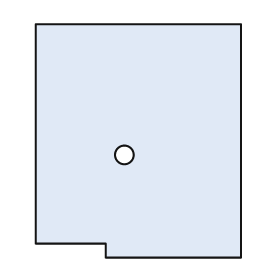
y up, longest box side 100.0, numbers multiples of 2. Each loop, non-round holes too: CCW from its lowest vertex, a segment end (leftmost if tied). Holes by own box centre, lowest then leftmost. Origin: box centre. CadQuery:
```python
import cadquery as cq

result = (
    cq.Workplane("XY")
    .moveTo(-14.0, -50.0)
    .lineTo(44.0, -50.0)
    .lineTo(44.0, 50.0)
    .lineTo(-44.0, 50.0)
    .lineTo(-44.0, -44.0)
    .lineTo(-14.0, -44.0)
    .close()
    .moveTo(-6.0, -6.0)
    .circle(4.0)
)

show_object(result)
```